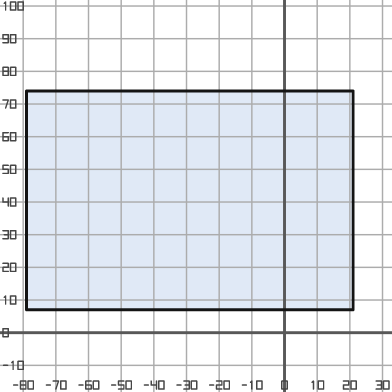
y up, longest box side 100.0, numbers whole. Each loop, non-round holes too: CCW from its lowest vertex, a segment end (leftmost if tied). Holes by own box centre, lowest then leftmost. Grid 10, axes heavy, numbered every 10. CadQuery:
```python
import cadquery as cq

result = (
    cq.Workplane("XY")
    .moveTo(-79.0, 7.0)
    .lineTo(21.0, 7.0)
    .lineTo(21.0, 74.0)
    .lineTo(-79.0, 74.0)
    .close()
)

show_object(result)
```